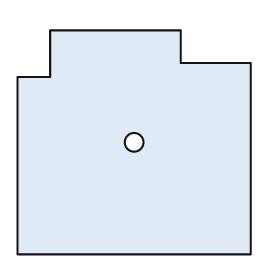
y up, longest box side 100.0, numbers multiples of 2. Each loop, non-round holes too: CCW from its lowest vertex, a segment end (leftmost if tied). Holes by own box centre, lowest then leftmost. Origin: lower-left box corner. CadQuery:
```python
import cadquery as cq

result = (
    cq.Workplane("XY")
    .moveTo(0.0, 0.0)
    .lineTo(100.0, 0.0)
    .lineTo(100.0, 82.0)
    .lineTo(70.0, 82.0)
    .lineTo(70.0, 96.0)
    .lineTo(14.0, 96.0)
    .lineTo(14.0, 76.0)
    .lineTo(0.0, 76.0)
    .close()
    .moveTo(50.0, 48.0)
    .circle(4.0)
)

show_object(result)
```